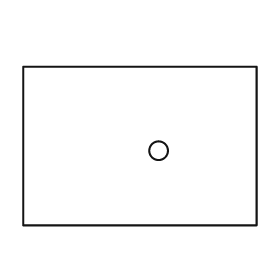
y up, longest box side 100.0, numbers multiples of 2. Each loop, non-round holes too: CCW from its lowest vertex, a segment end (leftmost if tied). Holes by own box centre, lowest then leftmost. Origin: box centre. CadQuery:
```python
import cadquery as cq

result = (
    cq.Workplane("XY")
    .moveTo(-50.0, -34.0)
    .lineTo(50.0, -34.0)
    .lineTo(50.0, 34.0)
    .lineTo(-50.0, 34.0)
    .close()
    .moveTo(8.0, -2.0)
    .circle(4.0)
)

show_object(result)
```